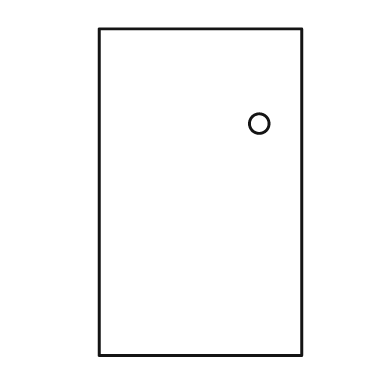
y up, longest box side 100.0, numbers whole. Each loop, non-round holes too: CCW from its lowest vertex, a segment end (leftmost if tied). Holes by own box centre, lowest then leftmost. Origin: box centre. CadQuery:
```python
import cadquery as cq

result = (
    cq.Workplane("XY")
    .moveTo(-31.0, -50.0)
    .lineTo(31.0, -50.0)
    .lineTo(31.0, 50.0)
    .lineTo(-31.0, 50.0)
    .close()
    .moveTo(18.0, 21.0)
    .circle(3.0)
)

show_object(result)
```